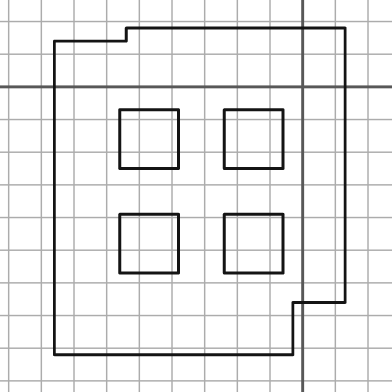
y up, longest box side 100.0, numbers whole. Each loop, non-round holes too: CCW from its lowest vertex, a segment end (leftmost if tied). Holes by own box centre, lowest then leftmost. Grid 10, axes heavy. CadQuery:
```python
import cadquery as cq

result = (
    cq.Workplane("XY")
    .moveTo(-76.0, -82.0)
    .lineTo(-3.0, -82.0)
    .lineTo(-3.0, -66.0)
    .lineTo(13.0, -66.0)
    .lineTo(13.0, 18.0)
    .lineTo(-54.0, 18.0)
    .lineTo(-54.0, 14.0)
    .lineTo(-76.0, 14.0)
    .close()
    .moveTo(-56.0, -57.0)
    .lineTo(-38.0, -57.0)
    .lineTo(-38.0, -39.0)
    .lineTo(-56.0, -39.0)
    .close()
    .moveTo(-24.0, -57.0)
    .lineTo(-6.0, -57.0)
    .lineTo(-6.0, -39.0)
    .lineTo(-24.0, -39.0)
    .close()
    .moveTo(-56.0, -25.0)
    .lineTo(-38.0, -25.0)
    .lineTo(-38.0, -7.0)
    .lineTo(-56.0, -7.0)
    .close()
    .moveTo(-24.0, -25.0)
    .lineTo(-6.0, -25.0)
    .lineTo(-6.0, -7.0)
    .lineTo(-24.0, -7.0)
    .close()
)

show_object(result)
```